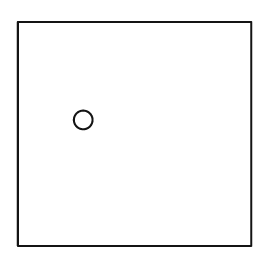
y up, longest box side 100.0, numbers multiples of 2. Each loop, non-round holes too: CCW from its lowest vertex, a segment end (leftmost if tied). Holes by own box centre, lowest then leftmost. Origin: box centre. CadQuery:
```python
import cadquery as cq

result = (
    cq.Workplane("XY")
    .moveTo(-50.0, -48.0)
    .lineTo(50.0, -48.0)
    .lineTo(50.0, 48.0)
    .lineTo(-50.0, 48.0)
    .close()
    .moveTo(-22.0, 6.0)
    .circle(4.0)
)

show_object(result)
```